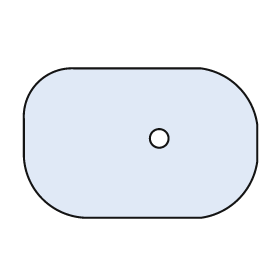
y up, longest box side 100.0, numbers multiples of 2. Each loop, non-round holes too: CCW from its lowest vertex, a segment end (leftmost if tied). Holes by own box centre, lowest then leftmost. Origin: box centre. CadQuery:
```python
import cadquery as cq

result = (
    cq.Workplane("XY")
    .moveTo(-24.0, -32.0)
    .lineTo(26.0, -32.0)
    .threePointArc((42.0, -24.0), (50.0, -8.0))
    .lineTo(50.0, 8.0)
    .threePointArc((42.0, 24.0), (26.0, 32.0))
    .lineTo(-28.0, 32.0)
    .threePointArc((-44.0, 26.0), (-50.0, 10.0))
    .lineTo(-50.0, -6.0)
    .threePointArc((-42.0, -24.0), (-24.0, -32.0))
    .close()
    .moveTo(8.0, 2.0)
    .circle(4.0)
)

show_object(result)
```